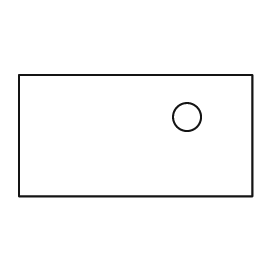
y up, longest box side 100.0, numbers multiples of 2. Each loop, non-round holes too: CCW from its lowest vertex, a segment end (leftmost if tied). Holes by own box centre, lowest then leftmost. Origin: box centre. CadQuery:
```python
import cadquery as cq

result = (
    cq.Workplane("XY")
    .moveTo(-50.0, -26.0)
    .lineTo(50.0, -26.0)
    .lineTo(50.0, 26.0)
    .lineTo(-50.0, 26.0)
    .close()
    .moveTo(22.0, 8.0)
    .circle(6.0)
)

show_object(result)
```